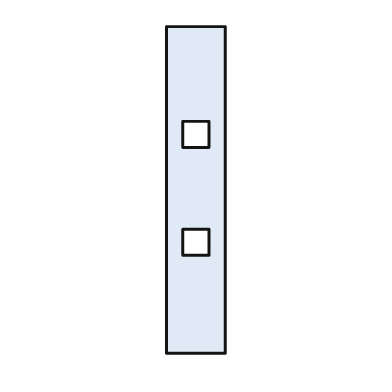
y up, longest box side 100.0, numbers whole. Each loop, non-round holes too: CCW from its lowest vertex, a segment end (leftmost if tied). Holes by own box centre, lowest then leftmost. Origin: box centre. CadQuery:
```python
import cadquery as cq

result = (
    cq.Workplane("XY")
    .moveTo(-9.0, -50.0)
    .lineTo(9.0, -50.0)
    .lineTo(9.0, 50.0)
    .lineTo(-9.0, 50.0)
    .close()
    .moveTo(-4.0, -20.0)
    .lineTo(4.0, -20.0)
    .lineTo(4.0, -12.0)
    .lineTo(-4.0, -12.0)
    .close()
    .moveTo(-4.0, 13.0)
    .lineTo(4.0, 13.0)
    .lineTo(4.0, 21.0)
    .lineTo(-4.0, 21.0)
    .close()
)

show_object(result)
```